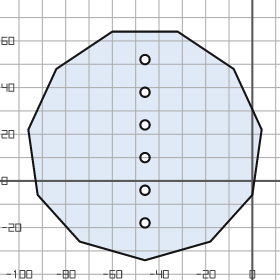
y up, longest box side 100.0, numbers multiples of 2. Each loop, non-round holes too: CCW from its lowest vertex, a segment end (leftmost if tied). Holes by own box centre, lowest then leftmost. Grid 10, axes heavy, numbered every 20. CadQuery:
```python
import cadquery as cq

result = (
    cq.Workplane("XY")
    .moveTo(-46.0, -34.0)
    .lineTo(-18.0, -26.0)
    .lineTo(0.0, -6.0)
    .lineTo(4.0, 22.0)
    .lineTo(-8.0, 48.0)
    .lineTo(-32.0, 64.0)
    .lineTo(-60.0, 64.0)
    .lineTo(-84.0, 48.0)
    .lineTo(-96.0, 22.0)
    .lineTo(-92.0, -6.0)
    .lineTo(-74.0, -26.0)
    .close()
    .moveTo(-46.0, -18.0)
    .circle(2.0)
    .moveTo(-46.0, -4.0)
    .circle(2.0)
    .moveTo(-46.0, 10.0)
    .circle(2.0)
    .moveTo(-46.0, 24.0)
    .circle(2.0)
    .moveTo(-46.0, 38.0)
    .circle(2.0)
    .moveTo(-46.0, 52.0)
    .circle(2.0)
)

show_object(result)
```